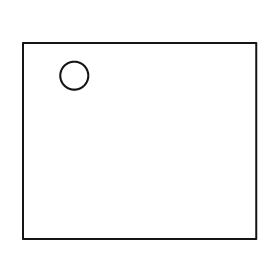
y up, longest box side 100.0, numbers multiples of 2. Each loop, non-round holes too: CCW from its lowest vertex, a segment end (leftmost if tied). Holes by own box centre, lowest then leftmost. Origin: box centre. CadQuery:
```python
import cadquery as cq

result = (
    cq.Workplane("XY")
    .moveTo(-50.0, -42.0)
    .lineTo(50.0, -42.0)
    .lineTo(50.0, 42.0)
    .lineTo(-50.0, 42.0)
    .close()
    .moveTo(-28.0, 28.0)
    .circle(6.0)
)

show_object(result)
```